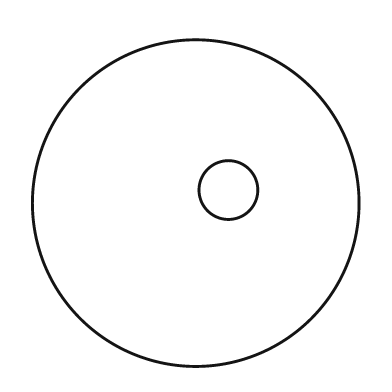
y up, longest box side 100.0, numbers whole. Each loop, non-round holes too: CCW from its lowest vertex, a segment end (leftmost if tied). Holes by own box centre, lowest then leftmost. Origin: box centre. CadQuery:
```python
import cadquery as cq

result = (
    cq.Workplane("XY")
    .moveTo(0.0, 0.0)
    .circle(50.0)
    .moveTo(10.0, 4.0)
    .circle(9.0)
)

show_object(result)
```